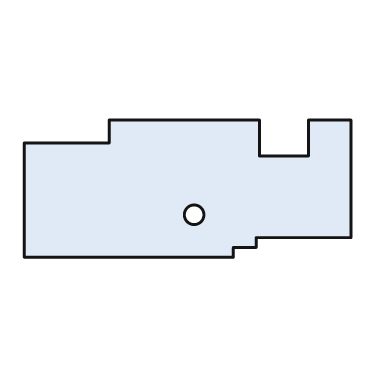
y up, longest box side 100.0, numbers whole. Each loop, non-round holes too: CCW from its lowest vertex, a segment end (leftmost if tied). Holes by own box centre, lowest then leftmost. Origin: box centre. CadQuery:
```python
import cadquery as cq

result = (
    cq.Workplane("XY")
    .moveTo(-50.0, -21.0)
    .lineTo(14.0, -21.0)
    .lineTo(14.0, -18.0)
    .lineTo(21.0, -18.0)
    .lineTo(21.0, -15.0)
    .lineTo(50.0, -15.0)
    .lineTo(50.0, 21.0)
    .lineTo(37.0, 21.0)
    .lineTo(37.0, 10.0)
    .lineTo(22.0, 10.0)
    .lineTo(22.0, 21.0)
    .lineTo(-24.0, 21.0)
    .lineTo(-24.0, 14.0)
    .lineTo(-50.0, 14.0)
    .close()
    .moveTo(2.0, -8.0)
    .circle(3.0)
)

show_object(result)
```